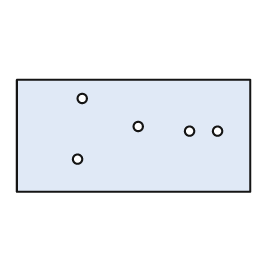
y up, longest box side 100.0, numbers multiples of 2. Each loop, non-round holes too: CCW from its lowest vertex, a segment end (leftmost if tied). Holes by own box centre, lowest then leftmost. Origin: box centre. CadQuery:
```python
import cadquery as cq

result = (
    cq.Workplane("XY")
    .moveTo(-50.0, -24.0)
    .lineTo(50.0, -24.0)
    .lineTo(50.0, 24.0)
    .lineTo(-50.0, 24.0)
    .close()
    .moveTo(-24.0, -10.0)
    .circle(2.0)
    .moveTo(24.0, 2.0)
    .circle(2.0)
    .moveTo(36.0, 2.0)
    .circle(2.0)
    .moveTo(2.0, 4.0)
    .circle(2.0)
    .moveTo(-22.0, 16.0)
    .circle(2.0)
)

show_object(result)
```